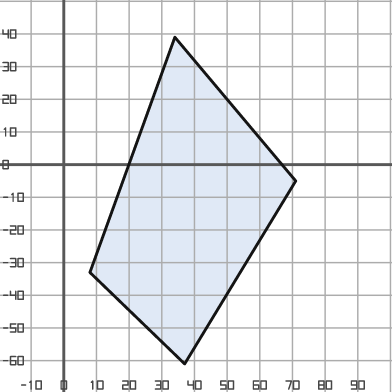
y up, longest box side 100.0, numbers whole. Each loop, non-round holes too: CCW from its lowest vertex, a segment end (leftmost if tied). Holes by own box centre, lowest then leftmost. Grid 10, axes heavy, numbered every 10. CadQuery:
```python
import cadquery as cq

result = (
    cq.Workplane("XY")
    .moveTo(37.0, -61.0)
    .lineTo(71.0, -5.0)
    .lineTo(34.0, 39.0)
    .lineTo(8.0, -33.0)
    .close()
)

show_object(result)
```